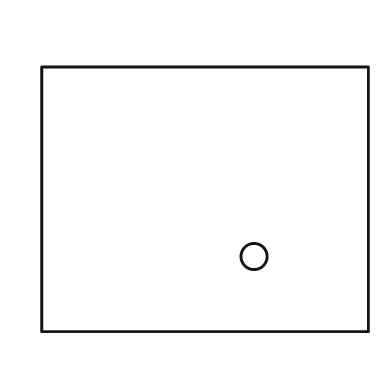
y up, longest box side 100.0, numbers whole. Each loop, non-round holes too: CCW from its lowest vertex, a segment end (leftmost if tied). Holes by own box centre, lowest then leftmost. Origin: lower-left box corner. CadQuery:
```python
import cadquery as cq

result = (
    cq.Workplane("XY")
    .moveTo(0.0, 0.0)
    .lineTo(100.0, 0.0)
    .lineTo(100.0, 81.0)
    .lineTo(0.0, 81.0)
    .close()
    .moveTo(65.0, 23.0)
    .circle(4.0)
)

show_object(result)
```